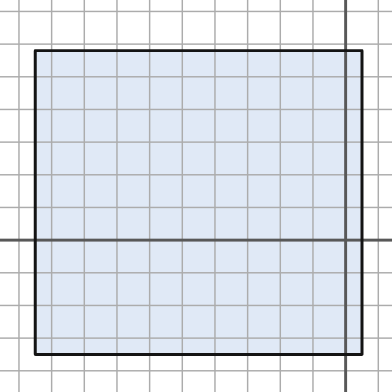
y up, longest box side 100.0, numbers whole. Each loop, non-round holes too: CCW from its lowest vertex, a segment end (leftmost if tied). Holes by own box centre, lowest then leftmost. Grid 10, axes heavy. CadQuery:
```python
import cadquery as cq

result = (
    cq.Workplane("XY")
    .moveTo(-95.0, -35.0)
    .lineTo(5.0, -35.0)
    .lineTo(5.0, 58.0)
    .lineTo(-95.0, 58.0)
    .close()
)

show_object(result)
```